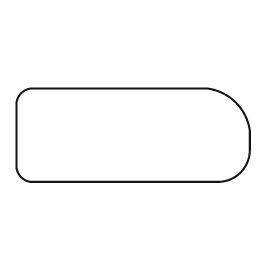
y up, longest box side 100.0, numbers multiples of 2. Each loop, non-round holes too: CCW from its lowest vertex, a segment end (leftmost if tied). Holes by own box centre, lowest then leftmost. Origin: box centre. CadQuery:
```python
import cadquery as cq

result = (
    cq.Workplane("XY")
    .moveTo(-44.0, -20.0)
    .lineTo(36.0, -20.0)
    .threePointArc((46.0, -16.0), (50.0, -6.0))
    .lineTo(50.0, 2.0)
    .threePointArc((44.0, 14.0), (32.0, 20.0))
    .lineTo(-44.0, 20.0)
    .threePointArc((-48.0, 18.0), (-50.0, 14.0))
    .lineTo(-50.0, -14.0)
    .threePointArc((-48.0, -18.0), (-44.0, -20.0))
    .close()
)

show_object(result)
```